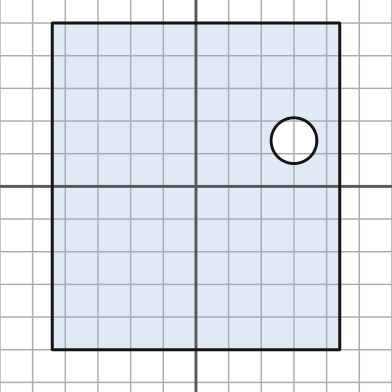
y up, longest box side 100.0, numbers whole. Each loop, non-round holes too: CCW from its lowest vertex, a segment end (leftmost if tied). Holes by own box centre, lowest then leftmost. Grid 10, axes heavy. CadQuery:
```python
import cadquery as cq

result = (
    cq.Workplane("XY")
    .moveTo(-44.0, -50.0)
    .lineTo(44.0, -50.0)
    .lineTo(44.0, 50.0)
    .lineTo(-44.0, 50.0)
    .close()
    .moveTo(30.0, 14.0)
    .circle(7.0)
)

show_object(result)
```